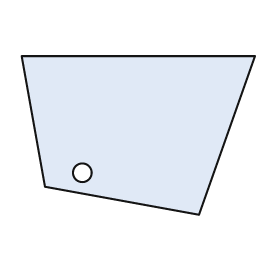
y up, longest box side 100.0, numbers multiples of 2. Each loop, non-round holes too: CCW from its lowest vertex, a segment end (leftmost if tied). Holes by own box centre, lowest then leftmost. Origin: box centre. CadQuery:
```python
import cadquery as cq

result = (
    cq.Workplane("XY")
    .moveTo(26.0, -34.0)
    .lineTo(50.0, 34.0)
    .lineTo(-50.0, 34.0)
    .lineTo(-40.0, -22.0)
    .close()
    .moveTo(-24.0, -16.0)
    .circle(4.0)
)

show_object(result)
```